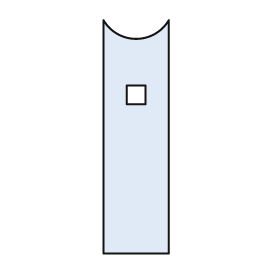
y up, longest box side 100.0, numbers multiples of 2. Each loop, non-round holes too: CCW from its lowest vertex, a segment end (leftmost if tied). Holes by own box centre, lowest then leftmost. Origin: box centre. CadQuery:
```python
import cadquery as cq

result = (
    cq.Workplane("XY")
    .moveTo(-14.0, -50.0)
    .lineTo(14.0, -50.0)
    .lineTo(14.0, 50.0)
    .threePointArc((0.0, 42.0), (-14.0, 50.0))
    .close()
    .moveTo(-4.0, 14.0)
    .lineTo(4.0, 14.0)
    .lineTo(4.0, 22.0)
    .lineTo(-4.0, 22.0)
    .close()
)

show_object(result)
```